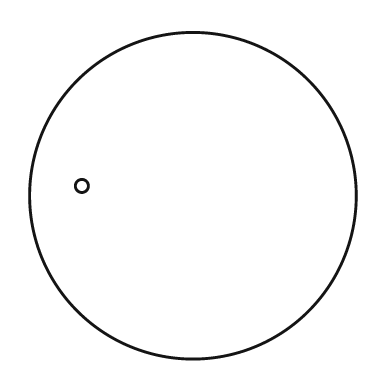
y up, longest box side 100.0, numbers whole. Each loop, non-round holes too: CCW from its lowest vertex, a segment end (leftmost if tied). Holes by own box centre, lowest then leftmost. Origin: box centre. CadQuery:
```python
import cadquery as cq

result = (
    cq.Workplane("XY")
    .moveTo(0.0, 0.0)
    .circle(50.0)
    .moveTo(-34.0, 3.0)
    .circle(2.0)
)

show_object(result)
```